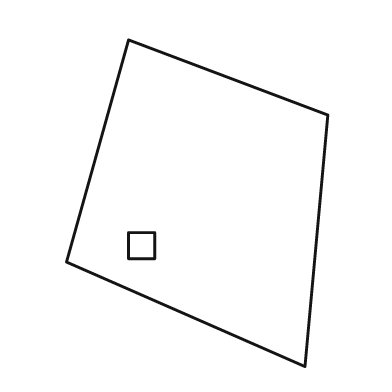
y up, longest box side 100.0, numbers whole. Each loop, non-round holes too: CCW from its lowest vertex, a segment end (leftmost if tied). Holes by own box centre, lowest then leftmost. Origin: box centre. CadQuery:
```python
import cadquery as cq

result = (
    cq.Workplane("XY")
    .moveTo(33.0, -50.0)
    .lineTo(40.0, 27.0)
    .lineTo(-21.0, 50.0)
    .lineTo(-40.0, -18.0)
    .close()
    .moveTo(-21.0, -17.0)
    .lineTo(-13.0, -17.0)
    .lineTo(-13.0, -9.0)
    .lineTo(-21.0, -9.0)
    .close()
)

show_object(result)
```